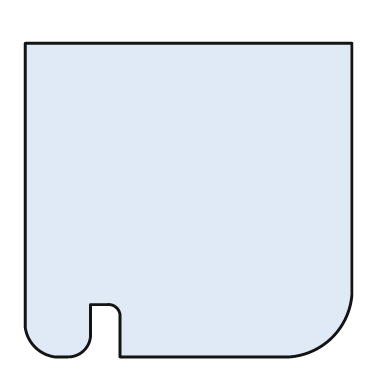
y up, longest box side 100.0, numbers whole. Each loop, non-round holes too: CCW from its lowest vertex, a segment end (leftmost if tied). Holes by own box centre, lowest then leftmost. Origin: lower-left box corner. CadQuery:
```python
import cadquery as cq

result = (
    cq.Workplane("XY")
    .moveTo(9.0, 0.0)
    .lineTo(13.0, 0.0)
    .threePointArc((18.0, 2.0), (20.0, 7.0))
    .lineTo(20.0, 16.0)
    .lineTo(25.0, 16.0)
    .threePointArc((28.0, 15.0), (29.0, 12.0))
    .lineTo(29.0, 0.0)
    .lineTo(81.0, 0.0)
    .threePointArc((94.0, 6.0), (100.0, 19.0))
    .lineTo(100.0, 96.0)
    .lineTo(0.0, 96.0)
    .lineTo(0.0, 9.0)
    .threePointArc((3.0, 3.0), (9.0, 0.0))
    .close()
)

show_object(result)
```